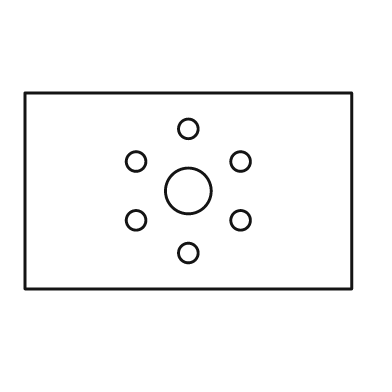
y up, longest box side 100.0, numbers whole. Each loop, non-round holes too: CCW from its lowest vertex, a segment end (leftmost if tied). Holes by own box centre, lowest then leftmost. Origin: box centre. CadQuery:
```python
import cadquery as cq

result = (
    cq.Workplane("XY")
    .moveTo(-50.0, -30.0)
    .lineTo(50.0, -30.0)
    .lineTo(50.0, 30.0)
    .lineTo(-50.0, 30.0)
    .close()
    .moveTo(0.0, -19.0)
    .circle(3.0)
    .moveTo(-16.0, -9.0)
    .circle(3.0)
    .moveTo(16.0, -9.0)
    .circle(3.0)
    .moveTo(0.0, 0.0)
    .circle(7.0)
    .moveTo(-16.0, 9.0)
    .circle(3.0)
    .moveTo(16.0, 9.0)
    .circle(3.0)
    .moveTo(0.0, 19.0)
    .circle(3.0)
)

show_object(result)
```